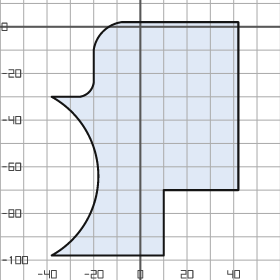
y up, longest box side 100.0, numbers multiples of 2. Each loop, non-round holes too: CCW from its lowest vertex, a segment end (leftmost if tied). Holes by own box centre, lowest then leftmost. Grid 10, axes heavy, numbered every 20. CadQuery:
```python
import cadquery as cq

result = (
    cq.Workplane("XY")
    .moveTo(-38.0, -98.0)
    .lineTo(10.0, -98.0)
    .lineTo(10.0, -70.0)
    .lineTo(42.0, -70.0)
    .lineTo(42.0, 2.0)
    .lineTo(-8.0, 2.0)
    .threePointArc((-16.0, -2.0), (-20.0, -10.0))
    .lineTo(-20.0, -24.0)
    .threePointArc((-22.0, -28.0), (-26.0, -30.0))
    .lineTo(-38.0, -30.0)
    .threePointArc((-18.0, -64.0), (-38.0, -98.0))
    .close()
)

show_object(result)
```